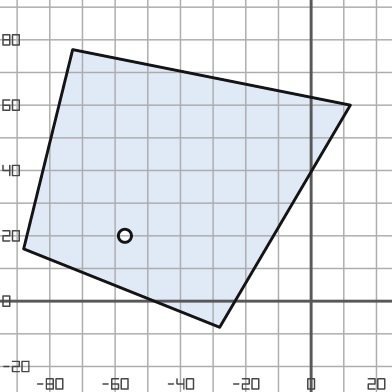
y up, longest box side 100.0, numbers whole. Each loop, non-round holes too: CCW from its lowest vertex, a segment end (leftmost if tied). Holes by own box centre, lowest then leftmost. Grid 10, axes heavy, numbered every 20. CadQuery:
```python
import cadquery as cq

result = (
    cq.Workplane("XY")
    .moveTo(-28.0, -8.0)
    .lineTo(12.0, 60.0)
    .lineTo(-73.0, 77.0)
    .lineTo(-88.0, 16.0)
    .close()
    .moveTo(-57.0, 20.0)
    .circle(2.0)
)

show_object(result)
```